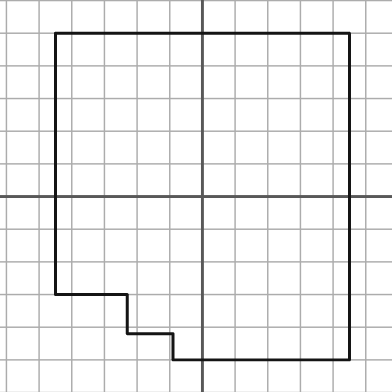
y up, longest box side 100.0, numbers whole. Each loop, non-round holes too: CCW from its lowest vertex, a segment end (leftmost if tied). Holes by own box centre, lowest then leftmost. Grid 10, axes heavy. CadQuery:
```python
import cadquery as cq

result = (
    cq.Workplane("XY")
    .moveTo(-9.0, -50.0)
    .lineTo(45.0, -50.0)
    .lineTo(45.0, 50.0)
    .lineTo(-45.0, 50.0)
    .lineTo(-45.0, -30.0)
    .lineTo(-23.0, -30.0)
    .lineTo(-23.0, -42.0)
    .lineTo(-9.0, -42.0)
    .close()
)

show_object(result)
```